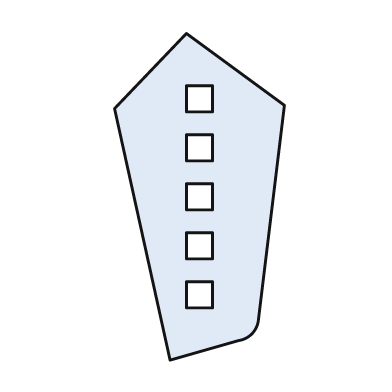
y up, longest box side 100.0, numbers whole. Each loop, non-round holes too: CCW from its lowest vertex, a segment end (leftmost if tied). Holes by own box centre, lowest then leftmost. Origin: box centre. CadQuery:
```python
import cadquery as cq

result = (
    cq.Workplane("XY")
    .moveTo(-9.0, -50.0)
    .lineTo(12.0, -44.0)
    .threePointArc((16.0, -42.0), (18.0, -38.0))
    .lineTo(26.0, 28.0)
    .lineTo(-4.0, 50.0)
    .lineTo(-26.0, 27.0)
    .close()
    .moveTo(-4.0, -34.0)
    .lineTo(4.0, -34.0)
    .lineTo(4.0, -26.0)
    .lineTo(-4.0, -26.0)
    .close()
    .moveTo(-4.0, -19.0)
    .lineTo(4.0, -19.0)
    .lineTo(4.0, -11.0)
    .lineTo(-4.0, -11.0)
    .close()
    .moveTo(-4.0, -4.0)
    .lineTo(4.0, -4.0)
    .lineTo(4.0, 4.0)
    .lineTo(-4.0, 4.0)
    .close()
    .moveTo(-4.0, 11.0)
    .lineTo(4.0, 11.0)
    .lineTo(4.0, 19.0)
    .lineTo(-4.0, 19.0)
    .close()
    .moveTo(-4.0, 26.0)
    .lineTo(4.0, 26.0)
    .lineTo(4.0, 34.0)
    .lineTo(-4.0, 34.0)
    .close()
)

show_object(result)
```